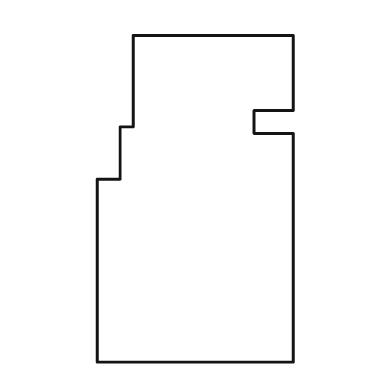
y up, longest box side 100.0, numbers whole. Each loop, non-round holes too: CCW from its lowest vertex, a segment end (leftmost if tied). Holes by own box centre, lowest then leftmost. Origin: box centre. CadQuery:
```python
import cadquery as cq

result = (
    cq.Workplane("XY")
    .moveTo(-30.0, -50.0)
    .lineTo(30.0, -50.0)
    .lineTo(30.0, 20.0)
    .lineTo(18.0, 20.0)
    .lineTo(18.0, 27.0)
    .lineTo(30.0, 27.0)
    .lineTo(30.0, 50.0)
    .lineTo(-19.0, 50.0)
    .lineTo(-19.0, 22.0)
    .lineTo(-23.0, 22.0)
    .lineTo(-23.0, 6.0)
    .lineTo(-30.0, 6.0)
    .close()
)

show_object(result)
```